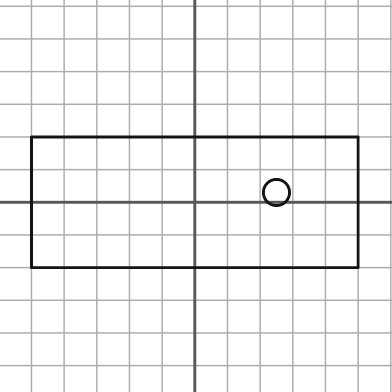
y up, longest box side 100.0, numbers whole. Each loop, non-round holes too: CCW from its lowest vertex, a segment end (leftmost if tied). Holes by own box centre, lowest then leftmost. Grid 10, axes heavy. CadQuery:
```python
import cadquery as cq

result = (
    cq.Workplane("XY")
    .moveTo(-50.0, -20.0)
    .lineTo(50.0, -20.0)
    .lineTo(50.0, 20.0)
    .lineTo(-50.0, 20.0)
    .close()
    .moveTo(25.0, 3.0)
    .circle(4.0)
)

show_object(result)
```